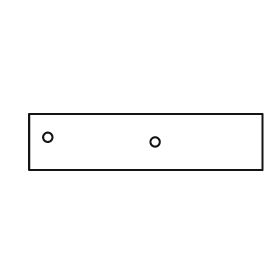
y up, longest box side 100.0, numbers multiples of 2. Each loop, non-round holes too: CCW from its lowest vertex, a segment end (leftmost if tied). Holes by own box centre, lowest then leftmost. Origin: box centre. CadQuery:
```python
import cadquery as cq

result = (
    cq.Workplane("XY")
    .moveTo(-50.0, -12.0)
    .lineTo(50.0, -12.0)
    .lineTo(50.0, 12.0)
    .lineTo(-50.0, 12.0)
    .close()
    .moveTo(4.0, 0.0)
    .circle(2.0)
    .moveTo(-42.0, 2.0)
    .circle(2.0)
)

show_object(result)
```